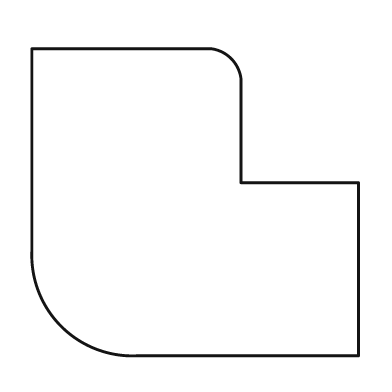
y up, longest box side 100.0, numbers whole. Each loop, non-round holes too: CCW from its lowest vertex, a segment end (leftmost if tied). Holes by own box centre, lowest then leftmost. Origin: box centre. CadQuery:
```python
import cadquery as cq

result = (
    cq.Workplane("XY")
    .moveTo(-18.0, -47.0)
    .lineTo(50.0, -47.0)
    .lineTo(50.0, 6.0)
    .lineTo(14.0, 6.0)
    .lineTo(14.0, 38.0)
    .threePointArc((11.0, 44.0), (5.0, 47.0))
    .lineTo(-50.0, 47.0)
    .lineTo(-50.0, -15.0)
    .threePointArc((-41.0, -38.0), (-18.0, -47.0))
    .close()
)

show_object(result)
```